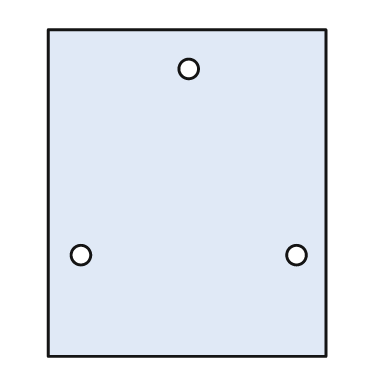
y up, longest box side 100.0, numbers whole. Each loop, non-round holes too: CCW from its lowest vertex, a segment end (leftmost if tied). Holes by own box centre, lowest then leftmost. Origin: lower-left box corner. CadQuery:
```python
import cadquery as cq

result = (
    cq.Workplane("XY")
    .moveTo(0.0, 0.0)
    .lineTo(85.0, 0.0)
    .lineTo(85.0, 100.0)
    .lineTo(0.0, 100.0)
    .close()
    .moveTo(10.0, 31.0)
    .circle(3.0)
    .moveTo(76.0, 31.0)
    .circle(3.0)
    .moveTo(43.0, 88.0)
    .circle(3.0)
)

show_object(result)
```